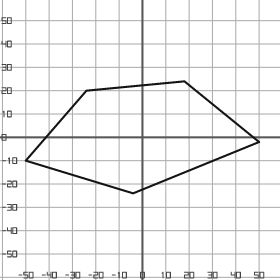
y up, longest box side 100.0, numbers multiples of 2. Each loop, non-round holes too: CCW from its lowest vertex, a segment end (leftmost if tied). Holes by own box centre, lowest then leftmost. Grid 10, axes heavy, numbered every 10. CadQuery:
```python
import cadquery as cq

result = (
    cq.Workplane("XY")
    .moveTo(-4.0, -24.0)
    .lineTo(50.0, -2.0)
    .lineTo(18.0, 24.0)
    .lineTo(-24.0, 20.0)
    .lineTo(-50.0, -10.0)
    .close()
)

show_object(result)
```